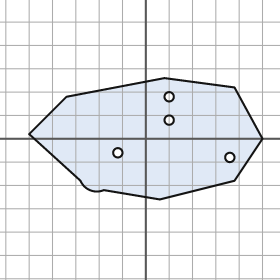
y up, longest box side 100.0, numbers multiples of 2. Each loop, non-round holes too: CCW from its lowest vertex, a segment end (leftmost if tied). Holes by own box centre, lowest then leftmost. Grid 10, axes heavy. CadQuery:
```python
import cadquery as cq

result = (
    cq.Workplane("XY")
    .moveTo(6.0, -26.0)
    .lineTo(38.0, -18.0)
    .lineTo(50.0, 0.0)
    .lineTo(38.0, 22.0)
    .lineTo(8.0, 26.0)
    .lineTo(-34.0, 18.0)
    .lineTo(-50.0, 2.0)
    .lineTo(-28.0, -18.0)
    .threePointArc((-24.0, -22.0), (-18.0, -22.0))
    .close()
    .moveTo(36.0, -8.0)
    .circle(2.0)
    .moveTo(-12.0, -6.0)
    .circle(2.0)
    .moveTo(10.0, 8.0)
    .circle(2.0)
    .moveTo(10.0, 18.0)
    .circle(2.0)
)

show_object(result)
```